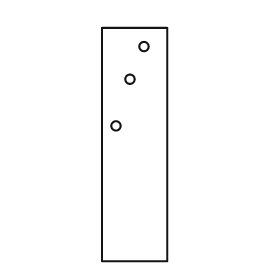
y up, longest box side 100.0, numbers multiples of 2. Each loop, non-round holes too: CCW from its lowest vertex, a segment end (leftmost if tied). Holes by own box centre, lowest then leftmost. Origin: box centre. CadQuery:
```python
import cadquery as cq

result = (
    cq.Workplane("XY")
    .moveTo(-14.0, -50.0)
    .lineTo(14.0, -50.0)
    .lineTo(14.0, 50.0)
    .lineTo(-14.0, 50.0)
    .close()
    .moveTo(-8.0, 8.0)
    .circle(2.0)
    .moveTo(-2.0, 28.0)
    .circle(2.0)
    .moveTo(4.0, 42.0)
    .circle(2.0)
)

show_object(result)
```